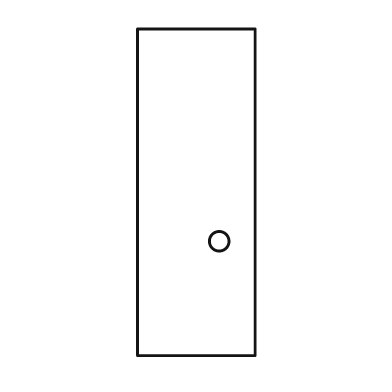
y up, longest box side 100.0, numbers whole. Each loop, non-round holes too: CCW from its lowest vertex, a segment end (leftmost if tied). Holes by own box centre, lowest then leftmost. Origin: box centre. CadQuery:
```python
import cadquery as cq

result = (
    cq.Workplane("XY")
    .moveTo(-18.0, -50.0)
    .lineTo(18.0, -50.0)
    .lineTo(18.0, 50.0)
    .lineTo(-18.0, 50.0)
    .close()
    .moveTo(7.0, -15.0)
    .circle(3.0)
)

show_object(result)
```